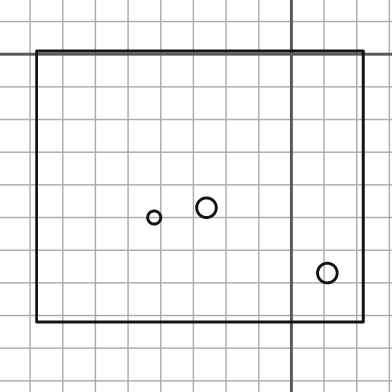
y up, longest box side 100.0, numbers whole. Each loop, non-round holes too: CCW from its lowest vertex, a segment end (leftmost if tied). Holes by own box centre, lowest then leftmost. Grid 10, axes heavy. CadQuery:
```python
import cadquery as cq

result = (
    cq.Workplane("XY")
    .moveTo(-78.0, -82.0)
    .lineTo(22.0, -82.0)
    .lineTo(22.0, 1.0)
    .lineTo(-78.0, 1.0)
    .close()
    .moveTo(11.0, -67.0)
    .circle(3.0)
    .moveTo(-42.0, -50.0)
    .circle(2.0)
    .moveTo(-26.0, -47.0)
    .circle(3.0)
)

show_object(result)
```